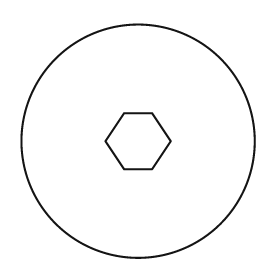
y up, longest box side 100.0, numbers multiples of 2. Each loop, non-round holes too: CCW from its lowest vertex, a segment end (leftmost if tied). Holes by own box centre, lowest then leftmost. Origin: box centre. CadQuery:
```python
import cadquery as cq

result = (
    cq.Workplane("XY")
    .moveTo(0.0, 0.0)
    .circle(50.0)
    .moveTo(-6.0, -12.0)
    .lineTo(6.0, -12.0)
    .lineTo(14.0, 0.0)
    .lineTo(6.0, 12.0)
    .lineTo(-6.0, 12.0)
    .lineTo(-14.0, 0.0)
    .close()
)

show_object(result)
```